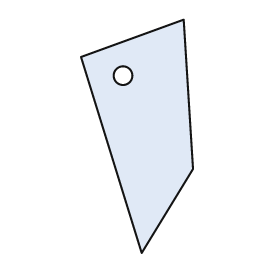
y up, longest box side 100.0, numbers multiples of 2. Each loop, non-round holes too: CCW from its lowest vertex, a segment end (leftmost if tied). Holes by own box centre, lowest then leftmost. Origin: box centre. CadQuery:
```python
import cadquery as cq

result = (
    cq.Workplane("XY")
    .moveTo(2.0, -50.0)
    .lineTo(24.0, -14.0)
    .lineTo(20.0, 50.0)
    .lineTo(-24.0, 34.0)
    .close()
    .moveTo(-6.0, 26.0)
    .circle(4.0)
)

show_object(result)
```